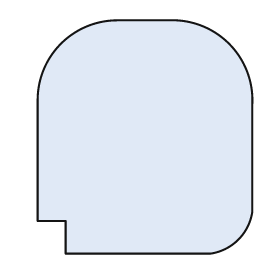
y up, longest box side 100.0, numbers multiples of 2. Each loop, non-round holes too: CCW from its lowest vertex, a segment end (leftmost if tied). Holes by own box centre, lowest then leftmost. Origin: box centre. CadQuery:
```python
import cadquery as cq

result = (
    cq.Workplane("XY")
    .moveTo(-34.0, -50.0)
    .lineTo(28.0, -50.0)
    .threePointArc((40.0, -44.0), (46.0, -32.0))
    .lineTo(46.0, 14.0)
    .threePointArc((36.0, 40.0), (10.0, 50.0))
    .lineTo(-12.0, 50.0)
    .threePointArc((-36.0, 40.0), (-46.0, 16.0))
    .lineTo(-46.0, -36.0)
    .lineTo(-34.0, -36.0)
    .close()
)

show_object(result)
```